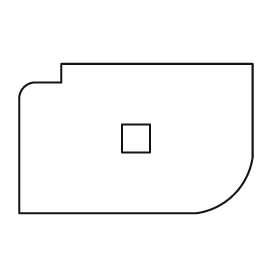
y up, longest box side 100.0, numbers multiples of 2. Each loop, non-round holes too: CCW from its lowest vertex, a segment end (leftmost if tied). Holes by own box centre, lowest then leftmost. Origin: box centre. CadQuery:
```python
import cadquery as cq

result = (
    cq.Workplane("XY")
    .moveTo(-50.0, -32.0)
    .lineTo(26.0, -32.0)
    .threePointArc((42.0, -24.0), (50.0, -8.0))
    .lineTo(50.0, 32.0)
    .lineTo(-32.0, 32.0)
    .lineTo(-32.0, 24.0)
    .lineTo(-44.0, 24.0)
    .threePointArc((-48.0, 22.0), (-50.0, 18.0))
    .close()
    .moveTo(-6.0, -6.0)
    .lineTo(6.0, -6.0)
    .lineTo(6.0, 6.0)
    .lineTo(-6.0, 6.0)
    .close()
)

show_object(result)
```